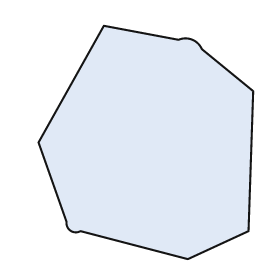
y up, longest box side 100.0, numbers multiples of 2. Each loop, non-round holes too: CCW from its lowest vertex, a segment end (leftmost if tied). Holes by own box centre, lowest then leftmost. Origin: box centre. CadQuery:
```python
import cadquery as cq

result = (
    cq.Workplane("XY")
    .moveTo(18.0, -50.0)
    .lineTo(44.0, -38.0)
    .lineTo(46.0, 22.0)
    .lineTo(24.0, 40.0)
    .threePointArc((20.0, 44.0), (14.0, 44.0))
    .lineTo(-18.0, 50.0)
    .lineTo(-46.0, 0.0)
    .lineTo(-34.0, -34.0)
    .threePointArc((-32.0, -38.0), (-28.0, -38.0))
    .close()
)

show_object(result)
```